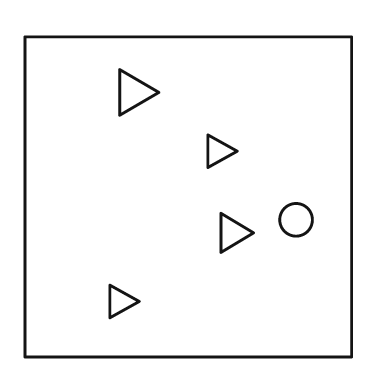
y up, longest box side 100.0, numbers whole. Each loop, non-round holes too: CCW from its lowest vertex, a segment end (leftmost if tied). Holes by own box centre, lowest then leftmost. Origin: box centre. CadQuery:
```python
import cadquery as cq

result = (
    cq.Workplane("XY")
    .moveTo(-50.0, -49.0)
    .lineTo(50.0, -49.0)
    .lineTo(50.0, 49.0)
    .lineTo(-50.0, 49.0)
    .close()
    .moveTo(-24.0, -37.0)
    .lineTo(-15.0, -32.0)
    .lineTo(-24.0, -27.0)
    .close()
    .moveTo(10.0, -17.0)
    .lineTo(20.0, -11.0)
    .lineTo(10.0, -5.0)
    .close()
    .moveTo(33.0, -7.0)
    .circle(5.0)
    .moveTo(6.0, 9.0)
    .lineTo(15.0, 14.0)
    .lineTo(6.0, 19.0)
    .close()
    .moveTo(-21.0, 25.0)
    .lineTo(-9.0, 32.0)
    .lineTo(-21.0, 39.0)
    .close()
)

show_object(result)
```